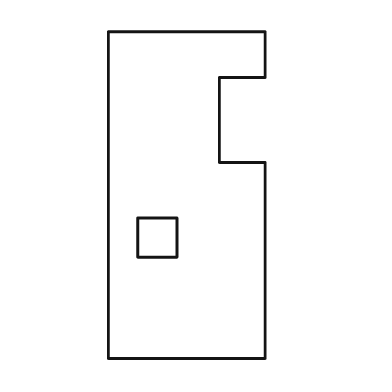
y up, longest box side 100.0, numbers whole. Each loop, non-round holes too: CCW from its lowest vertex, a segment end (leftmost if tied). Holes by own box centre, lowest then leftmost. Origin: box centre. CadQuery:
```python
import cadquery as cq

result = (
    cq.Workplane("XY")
    .moveTo(-24.0, -50.0)
    .lineTo(24.0, -50.0)
    .lineTo(24.0, 10.0)
    .lineTo(10.0, 10.0)
    .lineTo(10.0, 36.0)
    .lineTo(24.0, 36.0)
    .lineTo(24.0, 50.0)
    .lineTo(-24.0, 50.0)
    .close()
    .moveTo(-15.0, -19.0)
    .lineTo(-3.0, -19.0)
    .lineTo(-3.0, -7.0)
    .lineTo(-15.0, -7.0)
    .close()
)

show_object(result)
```